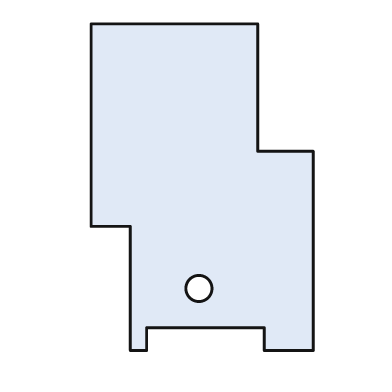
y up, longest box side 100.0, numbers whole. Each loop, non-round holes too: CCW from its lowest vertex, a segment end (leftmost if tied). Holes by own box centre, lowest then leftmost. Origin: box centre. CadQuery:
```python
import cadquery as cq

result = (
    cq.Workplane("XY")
    .moveTo(-22.0, -50.0)
    .lineTo(-17.0, -50.0)
    .lineTo(-17.0, -43.0)
    .lineTo(19.0, -43.0)
    .lineTo(19.0, -50.0)
    .lineTo(34.0, -50.0)
    .lineTo(34.0, 11.0)
    .lineTo(17.0, 11.0)
    .lineTo(17.0, 50.0)
    .lineTo(-34.0, 50.0)
    .lineTo(-34.0, -12.0)
    .lineTo(-22.0, -12.0)
    .close()
    .moveTo(-1.0, -31.0)
    .circle(4.0)
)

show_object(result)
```